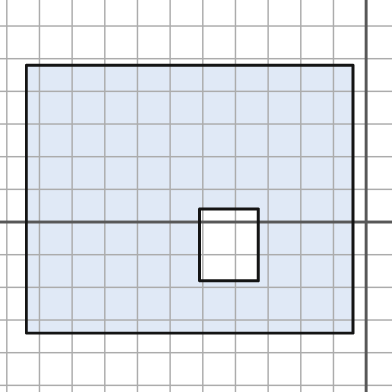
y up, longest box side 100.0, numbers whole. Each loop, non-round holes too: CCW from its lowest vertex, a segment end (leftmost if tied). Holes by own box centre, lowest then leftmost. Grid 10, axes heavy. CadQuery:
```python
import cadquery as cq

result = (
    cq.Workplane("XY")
    .moveTo(-104.0, -34.0)
    .lineTo(-4.0, -34.0)
    .lineTo(-4.0, 48.0)
    .lineTo(-104.0, 48.0)
    .close()
    .moveTo(-51.0, -18.0)
    .lineTo(-33.0, -18.0)
    .lineTo(-33.0, 4.0)
    .lineTo(-51.0, 4.0)
    .close()
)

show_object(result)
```